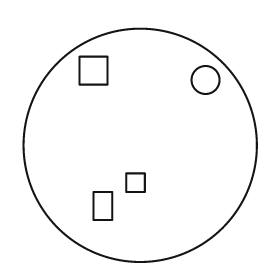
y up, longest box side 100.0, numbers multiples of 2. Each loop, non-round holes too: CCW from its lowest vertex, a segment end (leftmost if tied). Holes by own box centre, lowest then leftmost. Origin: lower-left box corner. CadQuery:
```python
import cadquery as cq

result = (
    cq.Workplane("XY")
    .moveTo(50.0, 50.0)
    .circle(50.0)
    .moveTo(30.0, 18.0)
    .lineTo(38.0, 18.0)
    .lineTo(38.0, 30.0)
    .lineTo(30.0, 30.0)
    .close()
    .moveTo(44.0, 30.0)
    .lineTo(52.0, 30.0)
    .lineTo(52.0, 38.0)
    .lineTo(44.0, 38.0)
    .close()
    .moveTo(78.0, 78.0)
    .circle(6.0)
    .moveTo(24.0, 76.0)
    .lineTo(36.0, 76.0)
    .lineTo(36.0, 88.0)
    .lineTo(24.0, 88.0)
    .close()
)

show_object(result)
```